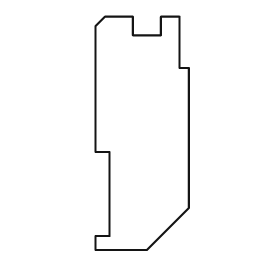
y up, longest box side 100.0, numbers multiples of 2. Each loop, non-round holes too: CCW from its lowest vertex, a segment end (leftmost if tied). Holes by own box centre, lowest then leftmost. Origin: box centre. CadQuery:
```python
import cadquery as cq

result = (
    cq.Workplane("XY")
    .moveTo(-20.0, -50.0)
    .lineTo(2.0, -50.0)
    .lineTo(20.0, -32.0)
    .lineTo(20.0, 28.0)
    .lineTo(16.0, 28.0)
    .lineTo(16.0, 50.0)
    .lineTo(8.0, 50.0)
    .lineTo(8.0, 42.0)
    .lineTo(-4.0, 42.0)
    .lineTo(-4.0, 50.0)
    .lineTo(-16.0, 50.0)
    .lineTo(-20.0, 46.0)
    .lineTo(-20.0, -8.0)
    .lineTo(-14.0, -8.0)
    .lineTo(-14.0, -44.0)
    .lineTo(-20.0, -44.0)
    .close()
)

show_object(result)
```